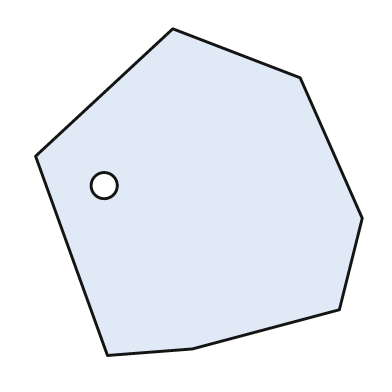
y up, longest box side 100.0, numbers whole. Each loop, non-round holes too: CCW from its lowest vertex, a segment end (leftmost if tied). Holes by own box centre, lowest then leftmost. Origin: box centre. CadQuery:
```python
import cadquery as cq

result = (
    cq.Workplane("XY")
    .moveTo(-28.0, -50.0)
    .lineTo(-2.0, -48.0)
    .lineTo(43.0, -36.0)
    .lineTo(50.0, -8.0)
    .lineTo(31.0, 35.0)
    .lineTo(-8.0, 50.0)
    .lineTo(-50.0, 11.0)
    .close()
    .moveTo(-29.0, 2.0)
    .circle(4.0)
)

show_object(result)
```